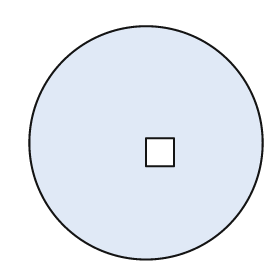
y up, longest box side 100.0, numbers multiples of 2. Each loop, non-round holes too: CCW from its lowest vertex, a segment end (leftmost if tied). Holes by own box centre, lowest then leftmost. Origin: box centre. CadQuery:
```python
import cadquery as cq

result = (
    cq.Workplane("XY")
    .moveTo(0.0, 0.0)
    .circle(50.0)
    .moveTo(0.0, -10.0)
    .lineTo(12.0, -10.0)
    .lineTo(12.0, 2.0)
    .lineTo(0.0, 2.0)
    .close()
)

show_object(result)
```